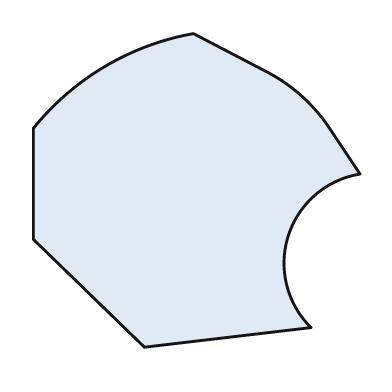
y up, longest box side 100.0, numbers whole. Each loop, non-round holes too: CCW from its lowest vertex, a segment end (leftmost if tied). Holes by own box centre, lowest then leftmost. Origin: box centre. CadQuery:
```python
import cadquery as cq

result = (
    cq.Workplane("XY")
    .moveTo(-16.0, -48.0)
    .lineTo(35.0, -42.0)
    .threePointArc((28.0, -14.0), (50.0, 5.0))
    .lineTo(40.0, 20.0)
    .threePointArc((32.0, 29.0), (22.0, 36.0))
    .lineTo(-1.0, 48.0)
    .threePointArc((-28.0, 38.0), (-50.0, 19.0))
    .lineTo(-50.0, -15.0)
    .close()
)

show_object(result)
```